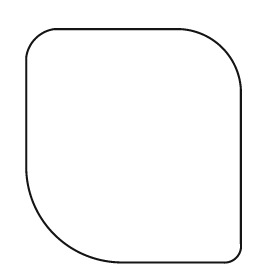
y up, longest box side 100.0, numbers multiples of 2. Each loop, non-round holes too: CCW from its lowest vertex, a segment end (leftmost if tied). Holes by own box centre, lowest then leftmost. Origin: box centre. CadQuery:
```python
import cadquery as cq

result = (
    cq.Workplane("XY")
    .moveTo(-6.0, -50.0)
    .lineTo(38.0, -50.0)
    .threePointArc((44.0, -48.0), (46.0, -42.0))
    .lineTo(46.0, 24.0)
    .threePointArc((38.0, 42.0), (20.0, 50.0))
    .lineTo(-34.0, 50.0)
    .threePointArc((-42.0, 46.0), (-46.0, 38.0))
    .lineTo(-46.0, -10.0)
    .threePointArc((-34.0, -38.0), (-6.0, -50.0))
    .close()
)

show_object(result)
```